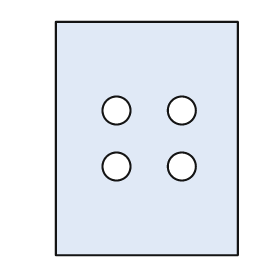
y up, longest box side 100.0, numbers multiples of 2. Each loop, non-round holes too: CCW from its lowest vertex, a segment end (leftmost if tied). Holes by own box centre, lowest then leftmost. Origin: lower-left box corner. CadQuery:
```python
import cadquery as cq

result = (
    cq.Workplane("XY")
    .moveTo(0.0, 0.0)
    .lineTo(78.0, 0.0)
    .lineTo(78.0, 100.0)
    .lineTo(0.0, 100.0)
    .close()
    .moveTo(26.0, 38.0)
    .circle(6.0)
    .moveTo(54.0, 38.0)
    .circle(6.0)
    .moveTo(26.0, 62.0)
    .circle(6.0)
    .moveTo(54.0, 62.0)
    .circle(6.0)
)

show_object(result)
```